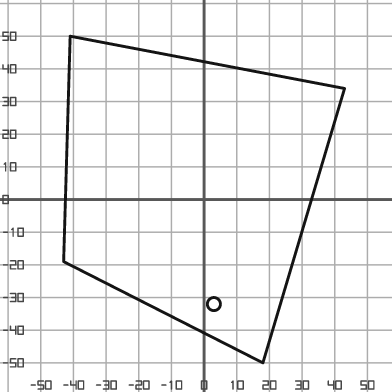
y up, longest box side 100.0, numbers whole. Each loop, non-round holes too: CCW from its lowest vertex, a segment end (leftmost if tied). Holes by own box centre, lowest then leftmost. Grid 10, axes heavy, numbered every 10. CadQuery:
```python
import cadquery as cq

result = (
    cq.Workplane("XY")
    .moveTo(18.0, -50.0)
    .lineTo(43.0, 34.0)
    .lineTo(-41.0, 50.0)
    .lineTo(-43.0, -19.0)
    .close()
    .moveTo(3.0, -32.0)
    .circle(2.0)
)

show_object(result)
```